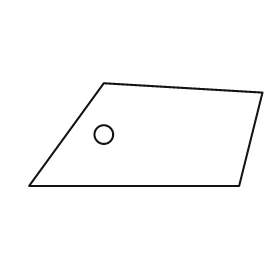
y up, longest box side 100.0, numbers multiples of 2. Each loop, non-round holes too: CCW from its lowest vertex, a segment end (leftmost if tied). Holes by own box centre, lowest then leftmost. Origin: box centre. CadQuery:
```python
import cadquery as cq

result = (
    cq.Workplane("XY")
    .moveTo(-50.0, -22.0)
    .lineTo(40.0, -22.0)
    .lineTo(50.0, 18.0)
    .lineTo(-18.0, 22.0)
    .close()
    .moveTo(-18.0, 0.0)
    .circle(4.0)
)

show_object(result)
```